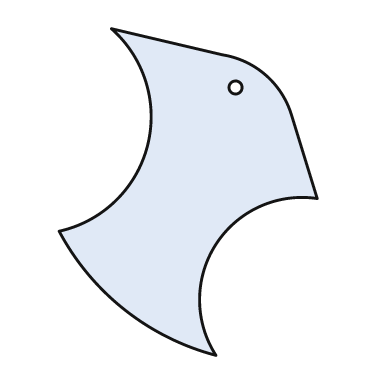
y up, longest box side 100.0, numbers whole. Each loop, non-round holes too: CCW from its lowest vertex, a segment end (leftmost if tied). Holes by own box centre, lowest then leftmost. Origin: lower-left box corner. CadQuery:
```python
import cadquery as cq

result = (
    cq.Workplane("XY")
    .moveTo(48.0, 0.0)
    .threePointArc((48.0, 34.0), (79.0, 48.0))
    .lineTo(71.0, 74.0)
    .threePointArc((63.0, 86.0), (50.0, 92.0))
    .lineTo(16.0, 100.0)
    .threePointArc((27.0, 64.0), (0.0, 38.0))
    .threePointArc((20.0, 14.0), (48.0, 0.0))
    .close()
    .moveTo(54.0, 82.0)
    .circle(2.0)
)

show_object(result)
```